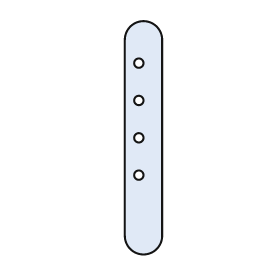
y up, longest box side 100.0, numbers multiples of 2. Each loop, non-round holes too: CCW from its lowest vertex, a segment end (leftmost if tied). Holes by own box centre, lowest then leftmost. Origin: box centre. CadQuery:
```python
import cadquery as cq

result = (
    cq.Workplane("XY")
    .moveTo(-8.0, -42.0)
    .threePointArc((0.0, -50.0), (8.0, -42.0))
    .lineTo(8.0, 42.0)
    .threePointArc((0.0, 50.0), (-8.0, 42.0))
    .close()
    .moveTo(-2.0, -16.0)
    .circle(2.0)
    .moveTo(-2.0, 0.0)
    .circle(2.0)
    .moveTo(-2.0, 16.0)
    .circle(2.0)
    .moveTo(-2.0, 32.0)
    .circle(2.0)
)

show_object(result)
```